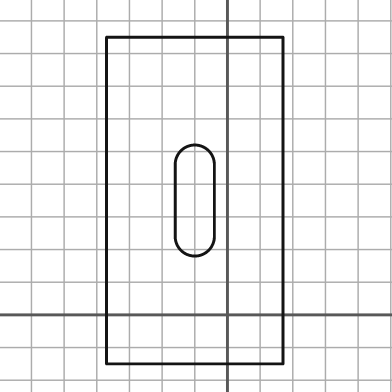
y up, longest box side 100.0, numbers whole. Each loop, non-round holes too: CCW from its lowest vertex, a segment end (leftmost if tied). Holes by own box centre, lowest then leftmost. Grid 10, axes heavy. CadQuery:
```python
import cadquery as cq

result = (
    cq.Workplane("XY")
    .moveTo(-37.0, -15.0)
    .lineTo(17.0, -15.0)
    .lineTo(17.0, 85.0)
    .lineTo(-37.0, 85.0)
    .close()
    .moveTo(-16.0, 24.0)
    .threePointArc((-10.0, 18.0), (-4.0, 24.0))
    .lineTo(-4.0, 46.0)
    .threePointArc((-10.0, 52.0), (-16.0, 46.0))
    .close()
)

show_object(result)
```